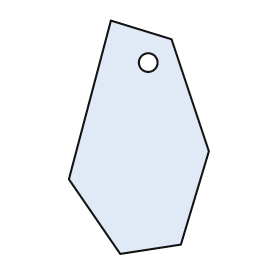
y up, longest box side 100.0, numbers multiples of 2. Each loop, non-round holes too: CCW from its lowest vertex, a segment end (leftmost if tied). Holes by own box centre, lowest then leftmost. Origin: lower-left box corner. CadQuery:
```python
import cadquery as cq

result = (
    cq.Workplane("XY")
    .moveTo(22.0, 0.0)
    .lineTo(48.0, 4.0)
    .lineTo(60.0, 44.0)
    .lineTo(44.0, 92.0)
    .lineTo(18.0, 100.0)
    .lineTo(0.0, 32.0)
    .close()
    .moveTo(34.0, 82.0)
    .circle(4.0)
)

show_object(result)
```